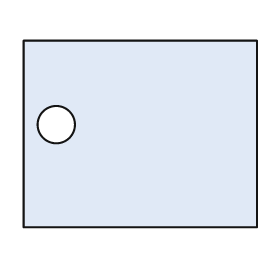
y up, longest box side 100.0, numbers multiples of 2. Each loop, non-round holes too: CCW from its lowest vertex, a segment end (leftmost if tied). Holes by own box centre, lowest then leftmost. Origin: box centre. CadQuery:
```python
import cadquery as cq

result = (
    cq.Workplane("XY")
    .moveTo(-50.0, -40.0)
    .lineTo(50.0, -40.0)
    .lineTo(50.0, 40.0)
    .lineTo(-50.0, 40.0)
    .close()
    .moveTo(-36.0, 4.0)
    .circle(8.0)
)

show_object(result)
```